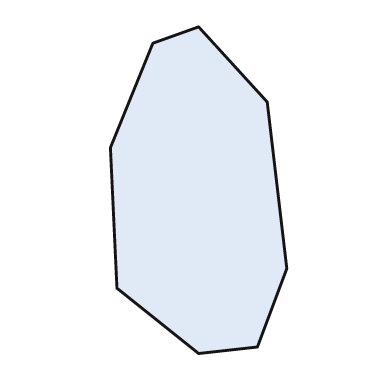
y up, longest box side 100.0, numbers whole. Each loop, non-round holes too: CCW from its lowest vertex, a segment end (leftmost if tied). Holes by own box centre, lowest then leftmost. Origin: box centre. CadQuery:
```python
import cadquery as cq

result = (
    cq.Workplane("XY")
    .moveTo(0.0, -50.0)
    .lineTo(18.0, -48.0)
    .lineTo(27.0, -24.0)
    .lineTo(21.0, 27.0)
    .lineTo(0.0, 50.0)
    .lineTo(-14.0, 45.0)
    .lineTo(-27.0, 13.0)
    .lineTo(-25.0, -30.0)
    .close()
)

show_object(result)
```